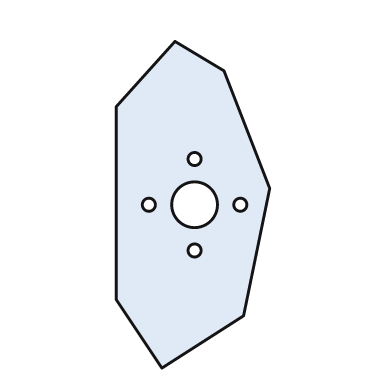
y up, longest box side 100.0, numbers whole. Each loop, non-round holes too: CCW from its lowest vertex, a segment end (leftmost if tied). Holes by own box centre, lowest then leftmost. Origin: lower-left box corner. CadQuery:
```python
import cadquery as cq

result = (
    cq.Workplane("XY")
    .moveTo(14.0, 0.0)
    .lineTo(39.0, 16.0)
    .lineTo(47.0, 55.0)
    .lineTo(33.0, 91.0)
    .lineTo(18.0, 100.0)
    .lineTo(0.0, 80.0)
    .lineTo(0.0, 21.0)
    .close()
    .moveTo(24.0, 36.0)
    .circle(2.0)
    .moveTo(10.0, 50.0)
    .circle(2.0)
    .moveTo(24.0, 50.0)
    .circle(7.0)
    .moveTo(38.0, 50.0)
    .circle(2.0)
    .moveTo(24.0, 64.0)
    .circle(2.0)
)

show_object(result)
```